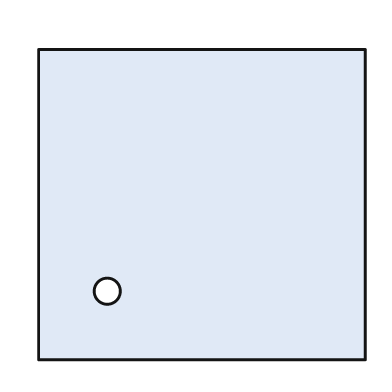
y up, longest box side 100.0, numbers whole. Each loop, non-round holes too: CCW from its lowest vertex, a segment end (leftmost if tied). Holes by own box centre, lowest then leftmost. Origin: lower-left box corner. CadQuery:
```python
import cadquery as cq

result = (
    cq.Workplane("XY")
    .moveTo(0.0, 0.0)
    .lineTo(100.0, 0.0)
    .lineTo(100.0, 95.0)
    .lineTo(0.0, 95.0)
    .close()
    .moveTo(21.0, 21.0)
    .circle(4.0)
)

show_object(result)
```